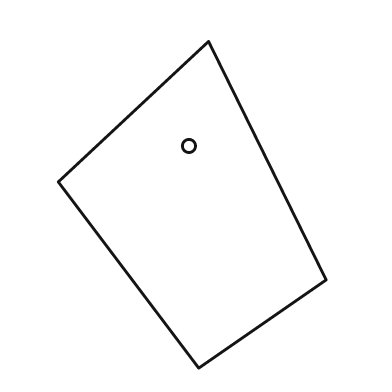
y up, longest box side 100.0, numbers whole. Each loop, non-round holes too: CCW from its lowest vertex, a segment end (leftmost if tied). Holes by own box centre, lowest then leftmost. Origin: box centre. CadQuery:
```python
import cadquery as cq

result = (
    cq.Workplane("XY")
    .moveTo(2.0, -50.0)
    .lineTo(41.0, -23.0)
    .lineTo(5.0, 50.0)
    .lineTo(-41.0, 7.0)
    .close()
    .moveTo(-1.0, 18.0)
    .circle(2.0)
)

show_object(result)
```